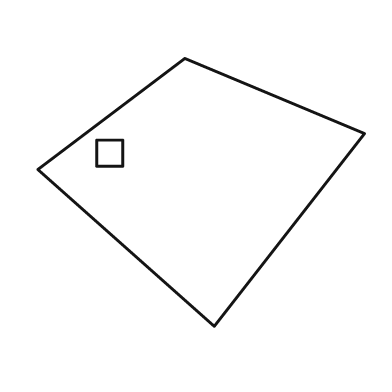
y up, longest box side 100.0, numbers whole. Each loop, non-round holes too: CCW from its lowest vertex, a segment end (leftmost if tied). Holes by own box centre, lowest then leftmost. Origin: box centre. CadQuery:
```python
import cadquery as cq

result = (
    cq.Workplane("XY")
    .moveTo(4.0, -41.0)
    .lineTo(50.0, 18.0)
    .lineTo(-5.0, 41.0)
    .lineTo(-50.0, 7.0)
    .close()
    .moveTo(-32.0, 8.0)
    .lineTo(-24.0, 8.0)
    .lineTo(-24.0, 16.0)
    .lineTo(-32.0, 16.0)
    .close()
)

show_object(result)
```